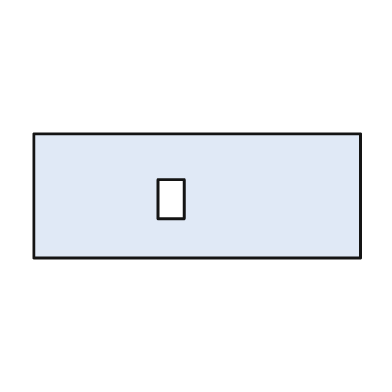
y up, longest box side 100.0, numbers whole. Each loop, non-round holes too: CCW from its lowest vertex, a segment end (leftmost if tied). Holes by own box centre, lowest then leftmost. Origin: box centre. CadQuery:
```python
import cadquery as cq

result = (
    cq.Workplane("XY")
    .moveTo(-50.0, -19.0)
    .lineTo(50.0, -19.0)
    .lineTo(50.0, 19.0)
    .lineTo(-50.0, 19.0)
    .close()
    .moveTo(-12.0, -7.0)
    .lineTo(-4.0, -7.0)
    .lineTo(-4.0, 5.0)
    .lineTo(-12.0, 5.0)
    .close()
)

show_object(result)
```